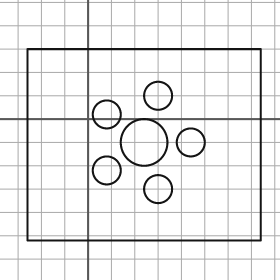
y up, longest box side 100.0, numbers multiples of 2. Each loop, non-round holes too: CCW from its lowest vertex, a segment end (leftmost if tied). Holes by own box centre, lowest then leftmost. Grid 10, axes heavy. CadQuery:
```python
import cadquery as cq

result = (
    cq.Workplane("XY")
    .moveTo(-26.0, -52.0)
    .lineTo(74.0, -52.0)
    .lineTo(74.0, 30.0)
    .lineTo(-26.0, 30.0)
    .close()
    .moveTo(30.0, -30.0)
    .circle(6.0)
    .moveTo(8.0, -22.0)
    .circle(6.0)
    .moveTo(24.0, -10.0)
    .circle(10.0)
    .moveTo(44.0, -10.0)
    .circle(6.0)
    .moveTo(8.0, 2.0)
    .circle(6.0)
    .moveTo(30.0, 10.0)
    .circle(6.0)
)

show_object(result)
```